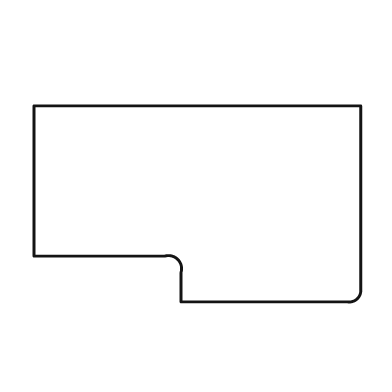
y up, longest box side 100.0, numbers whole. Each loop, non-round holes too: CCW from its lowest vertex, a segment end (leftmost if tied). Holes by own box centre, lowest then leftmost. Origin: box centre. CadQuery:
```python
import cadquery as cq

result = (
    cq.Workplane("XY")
    .moveTo(-5.0, -30.0)
    .lineTo(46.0, -30.0)
    .threePointArc((49.0, -29.0), (50.0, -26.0))
    .lineTo(50.0, 30.0)
    .lineTo(-50.0, 30.0)
    .lineTo(-50.0, -16.0)
    .lineTo(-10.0, -16.0)
    .threePointArc((-6.0, -17.0), (-5.0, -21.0))
    .close()
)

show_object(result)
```